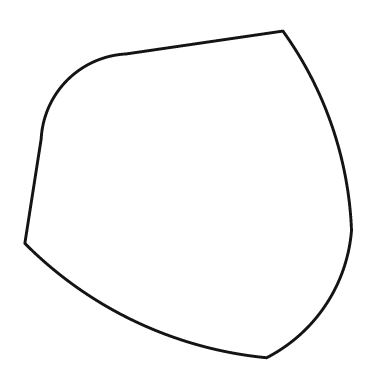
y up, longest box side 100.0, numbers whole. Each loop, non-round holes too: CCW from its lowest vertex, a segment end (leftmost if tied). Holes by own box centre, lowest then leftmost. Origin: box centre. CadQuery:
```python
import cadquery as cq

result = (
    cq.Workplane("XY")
    .moveTo(24.0, -50.0)
    .threePointArc((42.0, -34.0), (50.0, -11.0))
    .threePointArc((44.0, 21.0), (29.0, 50.0))
    .lineTo(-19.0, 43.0)
    .threePointArc((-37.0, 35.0), (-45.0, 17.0))
    .lineTo(-50.0, -15.0)
    .threePointArc((-16.0, -39.0), (24.0, -50.0))
    .close()
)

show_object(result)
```